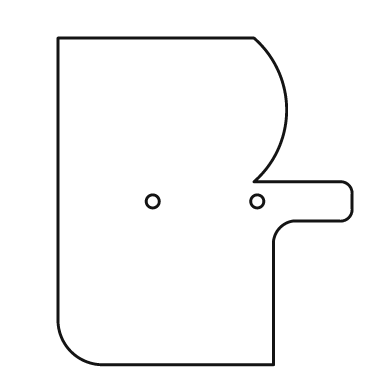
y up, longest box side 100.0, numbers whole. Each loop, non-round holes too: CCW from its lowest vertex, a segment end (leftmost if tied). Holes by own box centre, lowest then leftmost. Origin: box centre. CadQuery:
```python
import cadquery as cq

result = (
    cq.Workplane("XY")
    .moveTo(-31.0, -50.0)
    .lineTo(21.0, -50.0)
    .lineTo(21.0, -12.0)
    .threePointArc((23.0, -8.0), (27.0, -6.0))
    .lineTo(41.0, -6.0)
    .threePointArc((44.0, -5.0), (45.0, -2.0))
    .lineTo(45.0, 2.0)
    .threePointArc((44.0, 5.0), (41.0, 6.0))
    .lineTo(15.0, 6.0)
    .threePointArc((25.0, 28.0), (15.0, 50.0))
    .lineTo(-45.0, 50.0)
    .lineTo(-45.0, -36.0)
    .threePointArc((-41.0, -46.0), (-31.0, -50.0))
    .close()
    .moveTo(-16.0, 0.0)
    .circle(2.0)
    .moveTo(16.0, 0.0)
    .circle(2.0)
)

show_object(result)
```